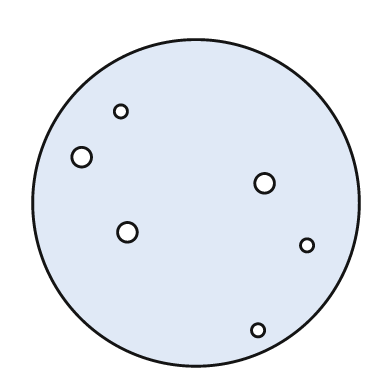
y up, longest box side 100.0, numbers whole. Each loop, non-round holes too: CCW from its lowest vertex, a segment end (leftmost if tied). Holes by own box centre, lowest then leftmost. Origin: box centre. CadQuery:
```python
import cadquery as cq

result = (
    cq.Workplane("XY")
    .moveTo(0.0, 0.0)
    .circle(50.0)
    .moveTo(19.0, -39.0)
    .circle(2.0)
    .moveTo(34.0, -13.0)
    .circle(2.0)
    .moveTo(-21.0, -9.0)
    .circle(3.0)
    .moveTo(21.0, 6.0)
    .circle(3.0)
    .moveTo(-35.0, 14.0)
    .circle(3.0)
    .moveTo(-23.0, 28.0)
    .circle(2.0)
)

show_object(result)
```